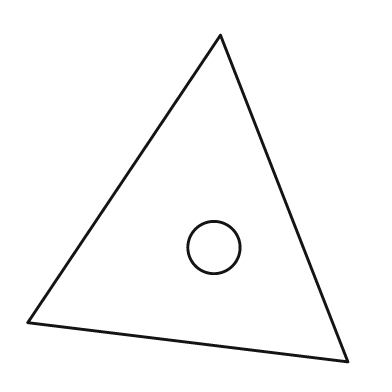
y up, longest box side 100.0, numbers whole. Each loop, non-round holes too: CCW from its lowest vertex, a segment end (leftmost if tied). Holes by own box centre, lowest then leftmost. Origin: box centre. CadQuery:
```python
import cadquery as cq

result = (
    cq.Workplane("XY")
    .moveTo(49.0, -50.0)
    .lineTo(10.0, 50.0)
    .lineTo(-49.0, -38.0)
    .close()
    .moveTo(8.0, -15.0)
    .circle(8.0)
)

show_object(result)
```